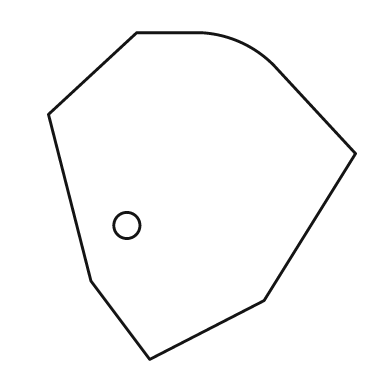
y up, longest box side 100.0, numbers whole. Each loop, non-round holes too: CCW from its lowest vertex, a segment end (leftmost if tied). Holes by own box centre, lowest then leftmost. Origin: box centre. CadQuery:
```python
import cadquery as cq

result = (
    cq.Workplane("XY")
    .moveTo(-16.0, -50.0)
    .lineTo(19.0, -32.0)
    .lineTo(47.0, 13.0)
    .lineTo(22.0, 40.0)
    .threePointArc((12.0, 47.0), (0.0, 50.0))
    .lineTo(-20.0, 50.0)
    .lineTo(-47.0, 25.0)
    .lineTo(-34.0, -26.0)
    .close()
    .moveTo(-23.0, -9.0)
    .circle(4.0)
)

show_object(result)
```